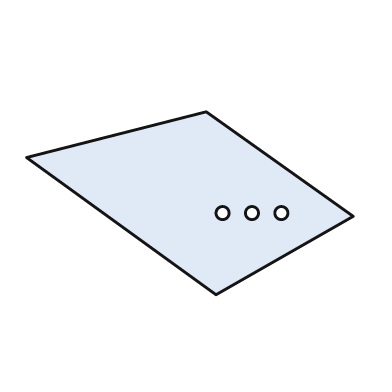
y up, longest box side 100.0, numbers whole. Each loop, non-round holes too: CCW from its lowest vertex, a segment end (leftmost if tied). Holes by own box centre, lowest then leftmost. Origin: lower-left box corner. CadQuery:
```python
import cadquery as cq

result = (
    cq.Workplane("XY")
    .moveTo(58.0, 0.0)
    .lineTo(100.0, 24.0)
    .lineTo(55.0, 56.0)
    .lineTo(0.0, 42.0)
    .close()
    .moveTo(60.0, 25.0)
    .circle(2.0)
    .moveTo(69.0, 25.0)
    .circle(2.0)
    .moveTo(78.0, 25.0)
    .circle(2.0)
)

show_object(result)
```